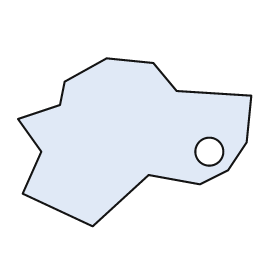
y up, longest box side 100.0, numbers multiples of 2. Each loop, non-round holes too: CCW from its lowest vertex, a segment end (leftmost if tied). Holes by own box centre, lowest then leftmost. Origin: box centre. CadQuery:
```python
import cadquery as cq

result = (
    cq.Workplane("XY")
    .moveTo(-18.0, -36.0)
    .lineTo(6.0, -14.0)
    .lineTo(28.0, -18.0)
    .lineTo(40.0, -12.0)
    .lineTo(48.0, 0.0)
    .lineTo(50.0, 20.0)
    .lineTo(18.0, 22.0)
    .lineTo(8.0, 34.0)
    .lineTo(-12.0, 36.0)
    .lineTo(-30.0, 26.0)
    .lineTo(-32.0, 16.0)
    .lineTo(-50.0, 10.0)
    .lineTo(-40.0, -4.0)
    .lineTo(-48.0, -22.0)
    .close()
    .moveTo(32.0, -4.0)
    .circle(6.0)
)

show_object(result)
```